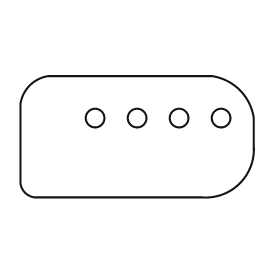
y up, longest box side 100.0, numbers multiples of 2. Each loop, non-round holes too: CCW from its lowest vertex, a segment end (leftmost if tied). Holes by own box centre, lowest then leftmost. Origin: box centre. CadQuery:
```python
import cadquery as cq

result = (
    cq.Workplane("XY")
    .moveTo(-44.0, -26.0)
    .lineTo(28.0, -26.0)
    .threePointArc((44.0, -20.0), (50.0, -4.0))
    .lineTo(50.0, 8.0)
    .threePointArc((44.0, 20.0), (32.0, 26.0))
    .lineTo(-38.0, 26.0)
    .threePointArc((-46.0, 22.0), (-50.0, 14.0))
    .lineTo(-50.0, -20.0)
    .threePointArc((-48.0, -24.0), (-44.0, -26.0))
    .close()
    .moveTo(-18.0, 8.0)
    .circle(4.0)
    .moveTo(0.0, 8.0)
    .circle(4.0)
    .moveTo(18.0, 8.0)
    .circle(4.0)
    .moveTo(36.0, 8.0)
    .circle(4.0)
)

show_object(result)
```